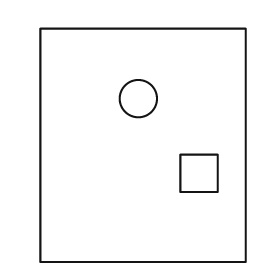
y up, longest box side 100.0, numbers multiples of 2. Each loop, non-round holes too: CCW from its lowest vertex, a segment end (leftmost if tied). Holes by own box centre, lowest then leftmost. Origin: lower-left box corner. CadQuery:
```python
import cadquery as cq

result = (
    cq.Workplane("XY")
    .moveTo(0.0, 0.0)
    .lineTo(88.0, 0.0)
    .lineTo(88.0, 100.0)
    .lineTo(0.0, 100.0)
    .close()
    .moveTo(60.0, 30.0)
    .lineTo(76.0, 30.0)
    .lineTo(76.0, 46.0)
    .lineTo(60.0, 46.0)
    .close()
    .moveTo(42.0, 70.0)
    .circle(8.0)
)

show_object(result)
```